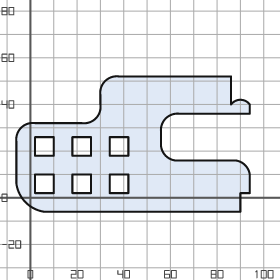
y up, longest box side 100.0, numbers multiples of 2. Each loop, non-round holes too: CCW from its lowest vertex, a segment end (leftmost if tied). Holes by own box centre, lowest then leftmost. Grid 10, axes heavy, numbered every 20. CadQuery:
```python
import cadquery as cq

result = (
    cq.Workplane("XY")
    .moveTo(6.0, -6.0)
    .lineTo(90.0, -6.0)
    .lineTo(90.0, 2.0)
    .lineTo(94.0, 2.0)
    .lineTo(94.0, 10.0)
    .threePointArc((92.0, 14.0), (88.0, 16.0))
    .lineTo(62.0, 16.0)
    .threePointArc((58.0, 18.0), (56.0, 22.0))
    .lineTo(56.0, 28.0)
    .threePointArc((58.0, 34.0), (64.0, 36.0))
    .lineTo(94.0, 36.0)
    .lineTo(94.0, 40.0)
    .threePointArc((90.0, 42.0), (86.0, 40.0))
    .lineTo(86.0, 52.0)
    .lineTo(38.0, 52.0)
    .threePointArc((32.0, 50.0), (30.0, 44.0))
    .lineTo(30.0, 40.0)
    .threePointArc((28.0, 34.0), (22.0, 32.0))
    .lineTo(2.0, 32.0)
    .threePointArc((-4.0, 30.0), (-6.0, 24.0))
    .lineTo(-6.0, 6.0)
    .threePointArc((-2.0, -2.0), (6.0, -6.0))
    .close()
    .moveTo(2.0, 2.0)
    .lineTo(10.0, 2.0)
    .lineTo(10.0, 10.0)
    .lineTo(2.0, 10.0)
    .close()
    .moveTo(18.0, 2.0)
    .lineTo(26.0, 2.0)
    .lineTo(26.0, 10.0)
    .lineTo(18.0, 10.0)
    .close()
    .moveTo(34.0, 2.0)
    .lineTo(42.0, 2.0)
    .lineTo(42.0, 10.0)
    .lineTo(34.0, 10.0)
    .close()
    .moveTo(2.0, 18.0)
    .lineTo(10.0, 18.0)
    .lineTo(10.0, 26.0)
    .lineTo(2.0, 26.0)
    .close()
    .moveTo(18.0, 18.0)
    .lineTo(26.0, 18.0)
    .lineTo(26.0, 26.0)
    .lineTo(18.0, 26.0)
    .close()
    .moveTo(34.0, 18.0)
    .lineTo(42.0, 18.0)
    .lineTo(42.0, 26.0)
    .lineTo(34.0, 26.0)
    .close()
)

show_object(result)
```